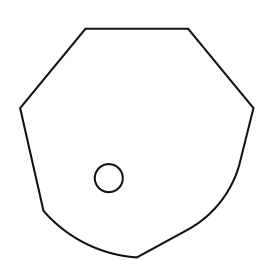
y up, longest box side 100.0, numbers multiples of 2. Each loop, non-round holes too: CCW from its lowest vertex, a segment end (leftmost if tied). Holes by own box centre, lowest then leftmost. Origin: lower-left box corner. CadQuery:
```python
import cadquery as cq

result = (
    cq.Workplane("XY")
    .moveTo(50.0, 0.0)
    .lineTo(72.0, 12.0)
    .threePointArc((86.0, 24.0), (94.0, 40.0))
    .lineTo(100.0, 64.0)
    .lineTo(72.0, 98.0)
    .lineTo(28.0, 98.0)
    .lineTo(0.0, 64.0)
    .lineTo(10.0, 20.0)
    .threePointArc((28.0, 6.0), (50.0, 0.0))
    .close()
    .moveTo(38.0, 34.0)
    .circle(6.0)
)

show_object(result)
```